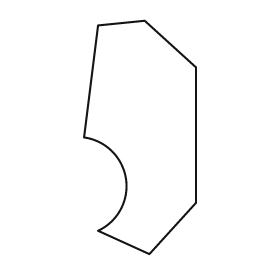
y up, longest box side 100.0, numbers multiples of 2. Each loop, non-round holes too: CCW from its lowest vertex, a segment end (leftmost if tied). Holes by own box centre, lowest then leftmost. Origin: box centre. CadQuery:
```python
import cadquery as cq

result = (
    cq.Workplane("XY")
    .moveTo(4.0, -50.0)
    .lineTo(24.0, -28.0)
    .lineTo(24.0, 30.0)
    .lineTo(2.0, 50.0)
    .lineTo(-18.0, 48.0)
    .lineTo(-24.0, 0.0)
    .threePointArc((-6.0, -18.0), (-18.0, -40.0))
    .close()
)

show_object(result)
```